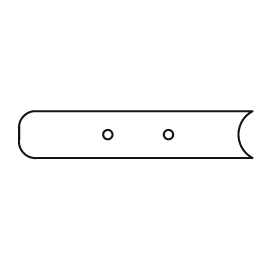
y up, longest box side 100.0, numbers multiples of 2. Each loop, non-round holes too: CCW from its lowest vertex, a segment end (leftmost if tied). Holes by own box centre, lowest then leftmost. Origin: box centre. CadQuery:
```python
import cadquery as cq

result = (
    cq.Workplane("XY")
    .moveTo(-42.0, -10.0)
    .lineTo(50.0, -10.0)
    .threePointArc((44.0, 0.0), (50.0, 10.0))
    .lineTo(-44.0, 10.0)
    .threePointArc((-48.0, 8.0), (-50.0, 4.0))
    .lineTo(-50.0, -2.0)
    .threePointArc((-48.0, -8.0), (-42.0, -10.0))
    .close()
    .moveTo(-12.0, 0.0)
    .circle(2.0)
    .moveTo(14.0, 0.0)
    .circle(2.0)
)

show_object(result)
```